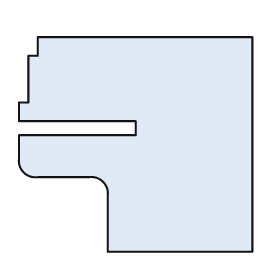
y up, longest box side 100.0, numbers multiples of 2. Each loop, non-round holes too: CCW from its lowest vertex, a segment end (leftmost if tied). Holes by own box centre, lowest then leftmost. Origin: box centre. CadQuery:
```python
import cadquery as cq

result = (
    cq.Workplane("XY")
    .moveTo(-12.0, -46.0)
    .lineTo(50.0, -46.0)
    .lineTo(50.0, 46.0)
    .lineTo(-42.0, 46.0)
    .lineTo(-42.0, 38.0)
    .lineTo(-46.0, 38.0)
    .lineTo(-46.0, 18.0)
    .lineTo(-50.0, 18.0)
    .lineTo(-50.0, 10.0)
    .lineTo(0.0, 10.0)
    .lineTo(0.0, 4.0)
    .lineTo(-50.0, 4.0)
    .lineTo(-50.0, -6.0)
    .threePointArc((-48.0, -12.0), (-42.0, -14.0))
    .lineTo(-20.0, -14.0)
    .threePointArc((-14.0, -16.0), (-12.0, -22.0))
    .close()
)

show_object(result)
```